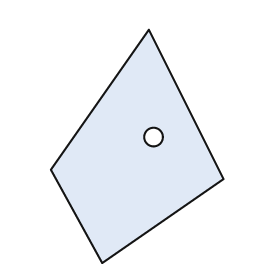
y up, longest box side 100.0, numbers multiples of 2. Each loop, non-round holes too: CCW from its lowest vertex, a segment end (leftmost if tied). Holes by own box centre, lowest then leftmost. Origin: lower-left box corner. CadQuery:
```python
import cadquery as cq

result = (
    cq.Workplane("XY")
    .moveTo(22.0, 0.0)
    .lineTo(74.0, 36.0)
    .lineTo(42.0, 100.0)
    .lineTo(0.0, 40.0)
    .close()
    .moveTo(44.0, 54.0)
    .circle(4.0)
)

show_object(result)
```